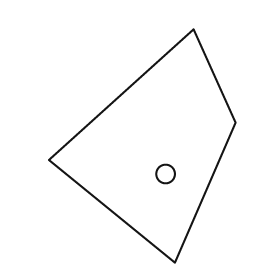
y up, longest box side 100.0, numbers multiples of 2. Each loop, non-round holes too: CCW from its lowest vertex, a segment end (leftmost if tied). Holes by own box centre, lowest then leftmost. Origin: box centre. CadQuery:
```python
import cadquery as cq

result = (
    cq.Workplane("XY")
    .moveTo(14.0, -50.0)
    .lineTo(40.0, 10.0)
    .lineTo(22.0, 50.0)
    .lineTo(-40.0, -6.0)
    .close()
    .moveTo(10.0, -12.0)
    .circle(4.0)
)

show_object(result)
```